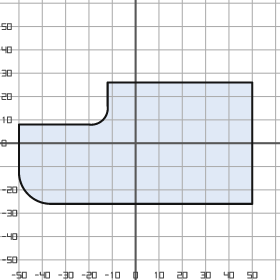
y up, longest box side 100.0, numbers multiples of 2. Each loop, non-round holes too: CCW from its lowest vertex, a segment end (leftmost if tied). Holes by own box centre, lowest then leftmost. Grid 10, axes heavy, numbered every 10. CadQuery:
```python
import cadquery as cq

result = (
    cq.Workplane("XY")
    .moveTo(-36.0, -26.0)
    .lineTo(50.0, -26.0)
    .lineTo(50.0, 26.0)
    .lineTo(-12.0, 26.0)
    .lineTo(-12.0, 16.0)
    .threePointArc((-14.0, 10.0), (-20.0, 8.0))
    .lineTo(-50.0, 8.0)
    .lineTo(-50.0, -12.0)
    .threePointArc((-46.0, -22.0), (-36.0, -26.0))
    .close()
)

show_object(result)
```